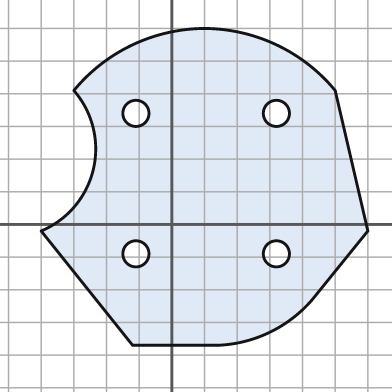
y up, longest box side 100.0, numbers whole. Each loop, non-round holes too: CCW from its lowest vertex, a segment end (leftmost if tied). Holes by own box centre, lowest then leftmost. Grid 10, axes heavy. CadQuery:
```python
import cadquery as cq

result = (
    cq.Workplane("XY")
    .moveTo(-12.0, -37.0)
    .lineTo(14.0, -37.0)
    .threePointArc((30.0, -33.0), (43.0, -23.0))
    .lineTo(60.0, -2.0)
    .lineTo(50.0, 41.0)
    .threePointArc((32.0, 55.0), (10.0, 60.0))
    .threePointArc((-12.0, 55.0), (-30.0, 41.0))
    .threePointArc((-24.0, 17.0), (-40.0, -2.0))
    .close()
    .moveTo(-11.0, -9.0)
    .circle(4.0)
    .moveTo(32.0, -9.0)
    .circle(4.0)
    .moveTo(-11.0, 34.0)
    .circle(4.0)
    .moveTo(32.0, 34.0)
    .circle(4.0)
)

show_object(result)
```